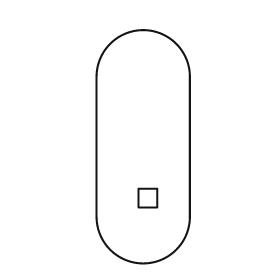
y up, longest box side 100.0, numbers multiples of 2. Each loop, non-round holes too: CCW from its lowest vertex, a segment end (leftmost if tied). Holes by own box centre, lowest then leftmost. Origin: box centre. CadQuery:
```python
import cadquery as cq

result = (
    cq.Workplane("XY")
    .moveTo(-20.0, -30.0)
    .threePointArc((0.0, -50.0), (20.0, -30.0))
    .lineTo(20.0, 30.0)
    .threePointArc((0.0, 50.0), (-20.0, 30.0))
    .close()
    .moveTo(-2.0, -26.0)
    .lineTo(6.0, -26.0)
    .lineTo(6.0, -18.0)
    .lineTo(-2.0, -18.0)
    .close()
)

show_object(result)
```